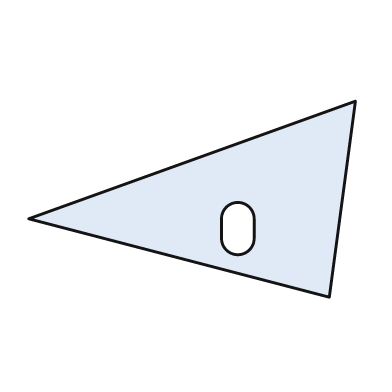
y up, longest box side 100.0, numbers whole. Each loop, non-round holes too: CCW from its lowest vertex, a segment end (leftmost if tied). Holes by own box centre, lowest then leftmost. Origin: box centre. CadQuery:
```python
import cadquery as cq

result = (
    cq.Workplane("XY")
    .moveTo(42.0, -30.0)
    .lineTo(50.0, 30.0)
    .lineTo(-50.0, -6.0)
    .close()
    .moveTo(9.0, -12.0)
    .threePointArc((14.0, -17.0), (19.0, -12.0))
    .lineTo(19.0, -6.0)
    .threePointArc((14.0, -1.0), (9.0, -6.0))
    .close()
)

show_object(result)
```